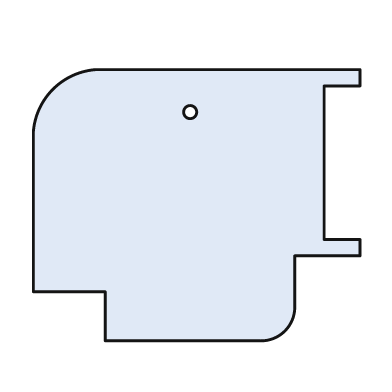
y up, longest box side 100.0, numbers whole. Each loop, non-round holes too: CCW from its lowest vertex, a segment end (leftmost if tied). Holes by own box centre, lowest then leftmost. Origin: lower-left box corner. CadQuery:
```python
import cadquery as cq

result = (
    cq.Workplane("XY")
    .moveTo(22.0, 0.0)
    .lineTo(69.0, 0.0)
    .threePointArc((77.0, 3.0), (80.0, 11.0))
    .lineTo(80.0, 26.0)
    .lineTo(100.0, 26.0)
    .lineTo(100.0, 31.0)
    .lineTo(89.0, 31.0)
    .lineTo(89.0, 78.0)
    .lineTo(100.0, 78.0)
    .lineTo(100.0, 83.0)
    .lineTo(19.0, 83.0)
    .threePointArc((6.0, 77.0), (0.0, 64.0))
    .lineTo(0.0, 15.0)
    .lineTo(22.0, 15.0)
    .close()
    .moveTo(48.0, 70.0)
    .circle(2.0)
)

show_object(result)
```